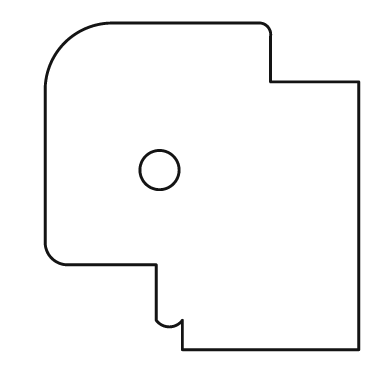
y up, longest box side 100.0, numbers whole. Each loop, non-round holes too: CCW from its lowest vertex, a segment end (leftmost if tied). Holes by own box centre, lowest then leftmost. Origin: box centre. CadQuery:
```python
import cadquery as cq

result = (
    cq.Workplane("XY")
    .moveTo(-6.0, -50.0)
    .lineTo(48.0, -50.0)
    .lineTo(48.0, 32.0)
    .lineTo(21.0, 32.0)
    .lineTo(21.0, 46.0)
    .threePointArc((20.0, 49.0), (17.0, 50.0))
    .lineTo(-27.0, 50.0)
    .threePointArc((-42.0, 44.0), (-48.0, 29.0))
    .lineTo(-48.0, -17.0)
    .threePointArc((-46.0, -22.0), (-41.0, -24.0))
    .lineTo(-14.0, -24.0)
    .lineTo(-14.0, -41.0)
    .threePointArc((-10.0, -43.0), (-6.0, -41.0))
    .close()
    .moveTo(-13.0, 5.0)
    .circle(6.0)
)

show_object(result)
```